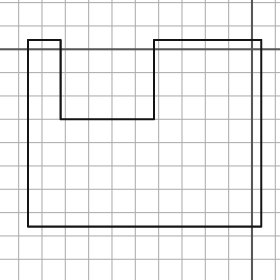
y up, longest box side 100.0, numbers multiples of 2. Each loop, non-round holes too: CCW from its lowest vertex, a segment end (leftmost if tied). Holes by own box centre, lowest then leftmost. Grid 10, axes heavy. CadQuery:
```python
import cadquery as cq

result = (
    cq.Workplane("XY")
    .moveTo(-96.0, -76.0)
    .lineTo(4.0, -76.0)
    .lineTo(4.0, 4.0)
    .lineTo(-42.0, 4.0)
    .lineTo(-42.0, -30.0)
    .lineTo(-82.0, -30.0)
    .lineTo(-82.0, 4.0)
    .lineTo(-96.0, 4.0)
    .close()
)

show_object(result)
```